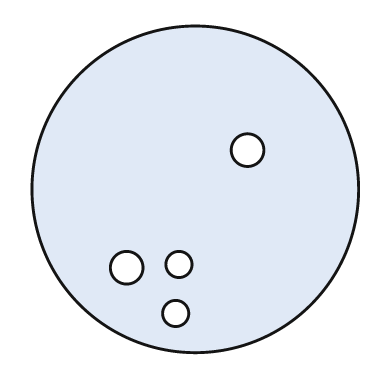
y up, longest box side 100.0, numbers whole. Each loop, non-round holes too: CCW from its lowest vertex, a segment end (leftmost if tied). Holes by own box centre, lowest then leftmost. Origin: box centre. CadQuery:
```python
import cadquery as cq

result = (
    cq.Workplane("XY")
    .moveTo(0.0, 0.0)
    .circle(50.0)
    .moveTo(-6.0, -38.0)
    .circle(4.0)
    .moveTo(-21.0, -24.0)
    .circle(5.0)
    .moveTo(-5.0, -23.0)
    .circle(4.0)
    .moveTo(16.0, 12.0)
    .circle(5.0)
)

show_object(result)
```